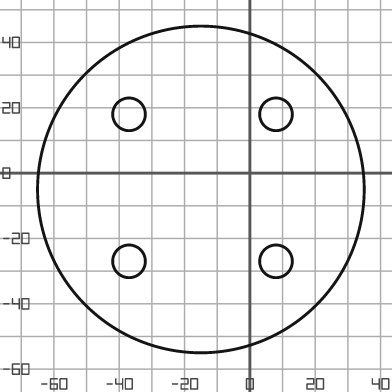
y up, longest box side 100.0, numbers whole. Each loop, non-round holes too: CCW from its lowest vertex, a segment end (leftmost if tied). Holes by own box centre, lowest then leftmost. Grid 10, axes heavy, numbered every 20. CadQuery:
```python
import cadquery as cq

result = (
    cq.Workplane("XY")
    .moveTo(-15.0, -5.0)
    .circle(50.0)
    .moveTo(-37.0, -27.0)
    .circle(5.0)
    .moveTo(8.0, -27.0)
    .circle(5.0)
    .moveTo(-37.0, 18.0)
    .circle(5.0)
    .moveTo(8.0, 18.0)
    .circle(5.0)
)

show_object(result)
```